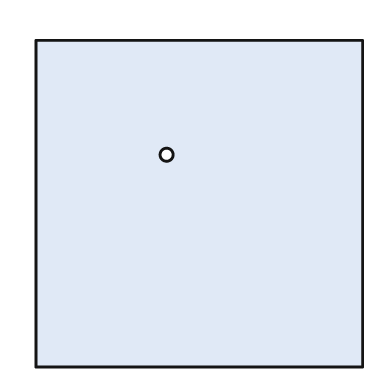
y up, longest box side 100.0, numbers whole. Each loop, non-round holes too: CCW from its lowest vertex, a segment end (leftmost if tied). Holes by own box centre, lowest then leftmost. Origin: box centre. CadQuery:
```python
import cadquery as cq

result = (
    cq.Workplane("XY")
    .moveTo(-50.0, -50.0)
    .lineTo(50.0, -50.0)
    .lineTo(50.0, 50.0)
    .lineTo(-50.0, 50.0)
    .close()
    .moveTo(-10.0, 15.0)
    .circle(2.0)
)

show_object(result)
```